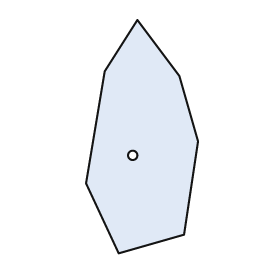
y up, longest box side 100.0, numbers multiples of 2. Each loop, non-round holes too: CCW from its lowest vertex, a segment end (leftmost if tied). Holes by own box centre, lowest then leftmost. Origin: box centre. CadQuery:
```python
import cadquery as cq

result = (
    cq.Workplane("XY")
    .moveTo(-10.0, -50.0)
    .lineTo(18.0, -42.0)
    .lineTo(24.0, -2.0)
    .lineTo(16.0, 26.0)
    .lineTo(-2.0, 50.0)
    .lineTo(-16.0, 28.0)
    .lineTo(-24.0, -20.0)
    .close()
    .moveTo(-4.0, -8.0)
    .circle(2.0)
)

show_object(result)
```